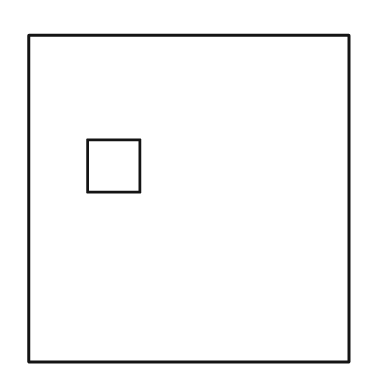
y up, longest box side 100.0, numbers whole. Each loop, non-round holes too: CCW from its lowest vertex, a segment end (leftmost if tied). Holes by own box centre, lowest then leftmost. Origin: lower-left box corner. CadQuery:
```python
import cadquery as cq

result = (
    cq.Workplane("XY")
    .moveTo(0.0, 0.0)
    .lineTo(98.0, 0.0)
    .lineTo(98.0, 100.0)
    .lineTo(0.0, 100.0)
    .close()
    .moveTo(18.0, 52.0)
    .lineTo(34.0, 52.0)
    .lineTo(34.0, 68.0)
    .lineTo(18.0, 68.0)
    .close()
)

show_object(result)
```